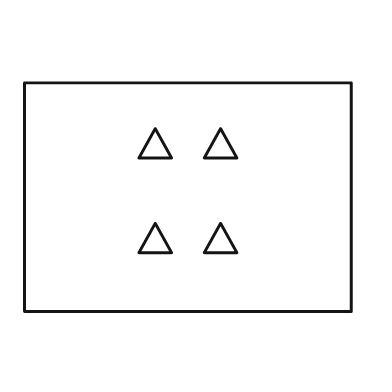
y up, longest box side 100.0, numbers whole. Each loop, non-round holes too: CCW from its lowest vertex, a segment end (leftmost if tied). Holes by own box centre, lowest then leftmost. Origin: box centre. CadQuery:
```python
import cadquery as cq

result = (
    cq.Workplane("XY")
    .moveTo(-50.0, -35.0)
    .lineTo(50.0, -35.0)
    .lineTo(50.0, 35.0)
    .lineTo(-50.0, 35.0)
    .close()
    .moveTo(-15.0, -17.0)
    .lineTo(-5.0, -17.0)
    .lineTo(-10.0, -8.0)
    .close()
    .moveTo(5.0, -17.0)
    .lineTo(15.0, -17.0)
    .lineTo(10.0, -8.0)
    .close()
    .moveTo(-15.0, 12.0)
    .lineTo(-5.0, 12.0)
    .lineTo(-10.0, 21.0)
    .close()
    .moveTo(5.0, 12.0)
    .lineTo(15.0, 12.0)
    .lineTo(10.0, 21.0)
    .close()
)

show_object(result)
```